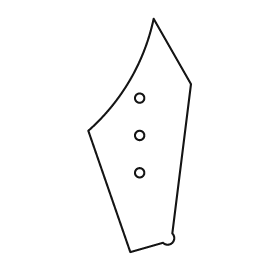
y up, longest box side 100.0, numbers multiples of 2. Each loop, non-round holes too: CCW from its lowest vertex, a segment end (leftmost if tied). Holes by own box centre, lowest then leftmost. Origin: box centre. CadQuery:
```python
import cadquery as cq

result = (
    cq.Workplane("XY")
    .moveTo(-4.0, -50.0)
    .lineTo(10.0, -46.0)
    .threePointArc((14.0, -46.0), (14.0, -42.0))
    .lineTo(22.0, 22.0)
    .lineTo(6.0, 50.0)
    .threePointArc((-4.0, 24.0), (-22.0, 2.0))
    .close()
    .moveTo(0.0, -16.0)
    .circle(2.0)
    .moveTo(0.0, 0.0)
    .circle(2.0)
    .moveTo(0.0, 16.0)
    .circle(2.0)
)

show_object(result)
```